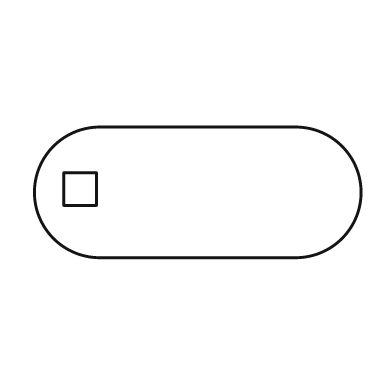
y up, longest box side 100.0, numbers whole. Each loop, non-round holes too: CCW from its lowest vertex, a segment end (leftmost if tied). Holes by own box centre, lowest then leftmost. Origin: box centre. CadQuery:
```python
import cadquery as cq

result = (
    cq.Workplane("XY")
    .moveTo(-30.0, -20.0)
    .lineTo(30.0, -20.0)
    .threePointArc((50.0, 0.0), (30.0, 20.0))
    .lineTo(-30.0, 20.0)
    .threePointArc((-50.0, 0.0), (-30.0, -20.0))
    .close()
    .moveTo(-41.0, -4.0)
    .lineTo(-31.0, -4.0)
    .lineTo(-31.0, 6.0)
    .lineTo(-41.0, 6.0)
    .close()
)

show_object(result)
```